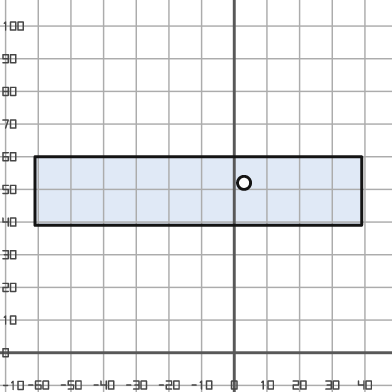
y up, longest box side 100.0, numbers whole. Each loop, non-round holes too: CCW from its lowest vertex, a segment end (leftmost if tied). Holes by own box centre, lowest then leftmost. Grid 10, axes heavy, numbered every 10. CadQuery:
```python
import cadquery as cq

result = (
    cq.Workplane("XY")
    .moveTo(-61.0, 39.0)
    .lineTo(39.0, 39.0)
    .lineTo(39.0, 60.0)
    .lineTo(-61.0, 60.0)
    .close()
    .moveTo(3.0, 52.0)
    .circle(2.0)
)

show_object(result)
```